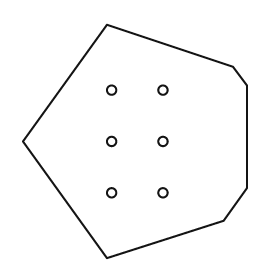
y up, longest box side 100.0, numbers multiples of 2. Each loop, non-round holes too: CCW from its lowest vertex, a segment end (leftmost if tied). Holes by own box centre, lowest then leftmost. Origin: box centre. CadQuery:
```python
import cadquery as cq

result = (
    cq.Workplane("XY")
    .moveTo(-12.0, -50.0)
    .lineTo(38.0, -34.0)
    .lineTo(48.0, -20.0)
    .lineTo(48.0, 24.0)
    .lineTo(42.0, 32.0)
    .lineTo(-12.0, 50.0)
    .lineTo(-48.0, 0.0)
    .close()
    .moveTo(-10.0, -22.0)
    .circle(2.0)
    .moveTo(12.0, -22.0)
    .circle(2.0)
    .moveTo(-10.0, 0.0)
    .circle(2.0)
    .moveTo(12.0, 0.0)
    .circle(2.0)
    .moveTo(-10.0, 22.0)
    .circle(2.0)
    .moveTo(12.0, 22.0)
    .circle(2.0)
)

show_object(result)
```